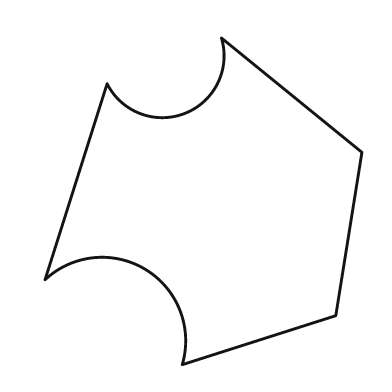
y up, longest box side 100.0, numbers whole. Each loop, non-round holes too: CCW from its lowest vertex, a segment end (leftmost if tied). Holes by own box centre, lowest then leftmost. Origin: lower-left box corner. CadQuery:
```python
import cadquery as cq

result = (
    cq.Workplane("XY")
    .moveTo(42.0, 0.0)
    .lineTo(89.0, 15.0)
    .lineTo(97.0, 65.0)
    .lineTo(54.0, 100.0)
    .threePointArc((43.0, 77.0), (19.0, 86.0))
    .lineTo(0.0, 26.0)
    .threePointArc((31.0, 29.0), (42.0, 0.0))
    .close()
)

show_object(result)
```